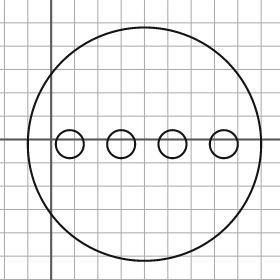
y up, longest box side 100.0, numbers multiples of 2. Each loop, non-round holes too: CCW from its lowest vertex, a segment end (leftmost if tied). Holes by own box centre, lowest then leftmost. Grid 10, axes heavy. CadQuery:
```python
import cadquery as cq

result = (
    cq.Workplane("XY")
    .moveTo(40.0, -2.0)
    .circle(50.0)
    .moveTo(8.0, -2.0)
    .circle(6.0)
    .moveTo(30.0, -2.0)
    .circle(6.0)
    .moveTo(52.0, -2.0)
    .circle(6.0)
    .moveTo(74.0, -2.0)
    .circle(6.0)
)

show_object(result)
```